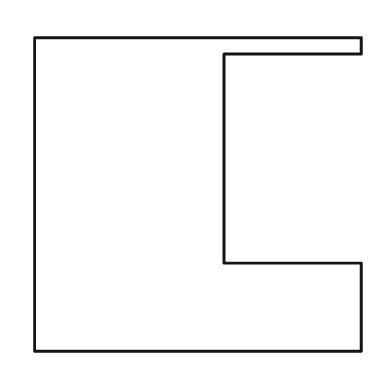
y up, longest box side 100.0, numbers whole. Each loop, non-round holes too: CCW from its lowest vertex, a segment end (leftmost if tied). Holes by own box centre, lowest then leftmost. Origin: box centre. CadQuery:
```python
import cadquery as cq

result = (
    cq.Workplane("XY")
    .moveTo(-50.0, -48.0)
    .lineTo(50.0, -48.0)
    .lineTo(50.0, -21.0)
    .lineTo(8.0, -21.0)
    .lineTo(8.0, 43.0)
    .lineTo(50.0, 43.0)
    .lineTo(50.0, 48.0)
    .lineTo(-50.0, 48.0)
    .close()
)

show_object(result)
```